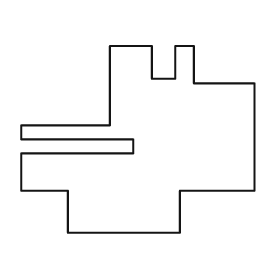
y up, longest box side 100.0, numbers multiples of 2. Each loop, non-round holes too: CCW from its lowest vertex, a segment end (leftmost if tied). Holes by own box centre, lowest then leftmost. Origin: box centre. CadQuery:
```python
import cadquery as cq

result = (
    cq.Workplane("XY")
    .moveTo(-30.0, -40.0)
    .lineTo(18.0, -40.0)
    .lineTo(18.0, -22.0)
    .lineTo(50.0, -22.0)
    .lineTo(50.0, 24.0)
    .lineTo(24.0, 24.0)
    .lineTo(24.0, 40.0)
    .lineTo(16.0, 40.0)
    .lineTo(16.0, 26.0)
    .lineTo(6.0, 26.0)
    .lineTo(6.0, 40.0)
    .lineTo(-12.0, 40.0)
    .lineTo(-12.0, 6.0)
    .lineTo(-50.0, 6.0)
    .lineTo(-50.0, 0.0)
    .lineTo(-2.0, 0.0)
    .lineTo(-2.0, -6.0)
    .lineTo(-50.0, -6.0)
    .lineTo(-50.0, -22.0)
    .lineTo(-30.0, -22.0)
    .close()
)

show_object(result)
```